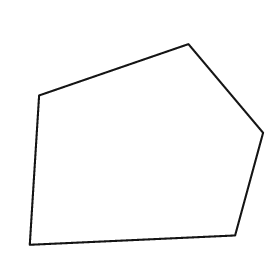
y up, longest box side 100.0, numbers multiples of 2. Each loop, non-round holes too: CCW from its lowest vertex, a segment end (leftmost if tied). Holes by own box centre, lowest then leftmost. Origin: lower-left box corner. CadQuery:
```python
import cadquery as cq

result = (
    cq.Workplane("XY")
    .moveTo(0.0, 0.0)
    .lineTo(88.0, 4.0)
    .lineTo(100.0, 48.0)
    .lineTo(68.0, 86.0)
    .lineTo(4.0, 64.0)
    .close()
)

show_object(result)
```